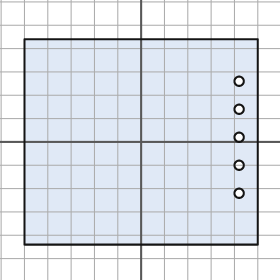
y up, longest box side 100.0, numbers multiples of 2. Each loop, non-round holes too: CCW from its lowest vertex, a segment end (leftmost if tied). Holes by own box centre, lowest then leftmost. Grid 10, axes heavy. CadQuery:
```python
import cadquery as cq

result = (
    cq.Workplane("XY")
    .moveTo(-50.0, -44.0)
    .lineTo(50.0, -44.0)
    .lineTo(50.0, 44.0)
    .lineTo(-50.0, 44.0)
    .close()
    .moveTo(42.0, -22.0)
    .circle(2.0)
    .moveTo(42.0, -10.0)
    .circle(2.0)
    .moveTo(42.0, 2.0)
    .circle(2.0)
    .moveTo(42.0, 14.0)
    .circle(2.0)
    .moveTo(42.0, 26.0)
    .circle(2.0)
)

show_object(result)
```